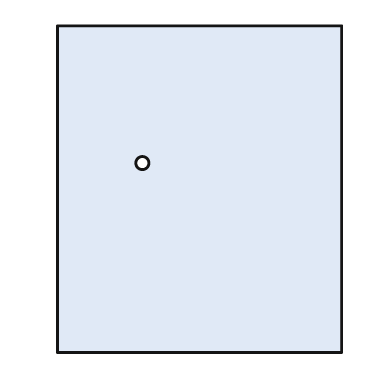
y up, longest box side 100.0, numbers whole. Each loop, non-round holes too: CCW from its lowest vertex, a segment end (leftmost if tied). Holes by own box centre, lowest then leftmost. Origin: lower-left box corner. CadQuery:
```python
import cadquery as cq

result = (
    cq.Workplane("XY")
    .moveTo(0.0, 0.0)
    .lineTo(87.0, 0.0)
    .lineTo(87.0, 100.0)
    .lineTo(0.0, 100.0)
    .close()
    .moveTo(26.0, 58.0)
    .circle(2.0)
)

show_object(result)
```